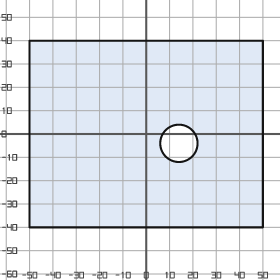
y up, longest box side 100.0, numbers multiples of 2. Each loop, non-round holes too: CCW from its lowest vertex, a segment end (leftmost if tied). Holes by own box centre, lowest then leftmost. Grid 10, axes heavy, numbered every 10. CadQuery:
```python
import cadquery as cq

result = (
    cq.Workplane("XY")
    .moveTo(-50.0, -40.0)
    .lineTo(50.0, -40.0)
    .lineTo(50.0, 40.0)
    .lineTo(-50.0, 40.0)
    .close()
    .moveTo(14.0, -4.0)
    .circle(8.0)
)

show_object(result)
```